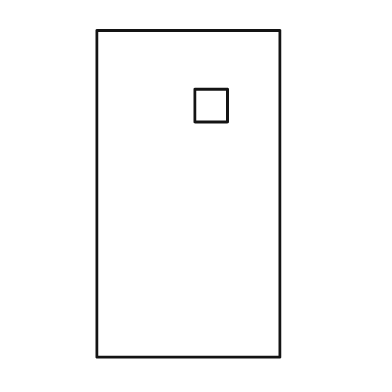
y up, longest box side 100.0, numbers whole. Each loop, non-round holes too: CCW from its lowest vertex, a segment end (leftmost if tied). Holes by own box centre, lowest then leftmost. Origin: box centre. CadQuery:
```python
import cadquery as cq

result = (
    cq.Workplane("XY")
    .moveTo(-28.0, -50.0)
    .lineTo(28.0, -50.0)
    .lineTo(28.0, 50.0)
    .lineTo(-28.0, 50.0)
    .close()
    .moveTo(2.0, 22.0)
    .lineTo(12.0, 22.0)
    .lineTo(12.0, 32.0)
    .lineTo(2.0, 32.0)
    .close()
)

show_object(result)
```